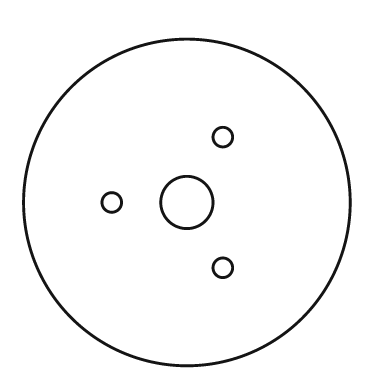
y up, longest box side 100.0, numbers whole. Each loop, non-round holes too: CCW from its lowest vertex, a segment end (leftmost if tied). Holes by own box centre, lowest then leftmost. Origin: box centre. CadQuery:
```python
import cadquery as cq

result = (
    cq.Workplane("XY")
    .moveTo(0.0, 0.0)
    .circle(50.0)
    .moveTo(11.0, -20.0)
    .circle(3.0)
    .moveTo(-23.0, 0.0)
    .circle(3.0)
    .moveTo(0.0, 0.0)
    .circle(8.0)
    .moveTo(11.0, 20.0)
    .circle(3.0)
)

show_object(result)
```